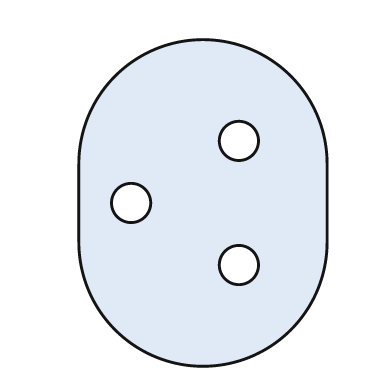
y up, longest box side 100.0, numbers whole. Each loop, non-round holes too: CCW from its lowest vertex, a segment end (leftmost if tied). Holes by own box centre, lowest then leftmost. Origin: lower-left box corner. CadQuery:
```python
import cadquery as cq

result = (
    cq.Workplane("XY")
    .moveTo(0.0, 38.0)
    .threePointArc((38.0, 0.0), (76.0, 38.0))
    .lineTo(76.0, 62.0)
    .threePointArc((38.0, 100.0), (0.0, 62.0))
    .close()
    .moveTo(49.0, 31.0)
    .circle(6.0)
    .moveTo(16.0, 50.0)
    .circle(6.0)
    .moveTo(49.0, 69.0)
    .circle(6.0)
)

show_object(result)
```